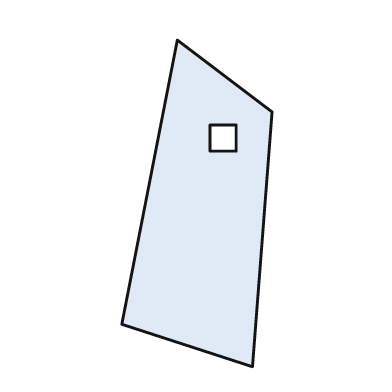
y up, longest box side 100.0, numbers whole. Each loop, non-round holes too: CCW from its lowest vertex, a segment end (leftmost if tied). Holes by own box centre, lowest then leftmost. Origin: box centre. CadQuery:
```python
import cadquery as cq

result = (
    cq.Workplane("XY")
    .moveTo(17.0, -50.0)
    .lineTo(23.0, 28.0)
    .lineTo(-6.0, 50.0)
    .lineTo(-23.0, -37.0)
    .close()
    .moveTo(4.0, 16.0)
    .lineTo(12.0, 16.0)
    .lineTo(12.0, 24.0)
    .lineTo(4.0, 24.0)
    .close()
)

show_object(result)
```